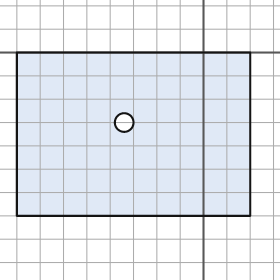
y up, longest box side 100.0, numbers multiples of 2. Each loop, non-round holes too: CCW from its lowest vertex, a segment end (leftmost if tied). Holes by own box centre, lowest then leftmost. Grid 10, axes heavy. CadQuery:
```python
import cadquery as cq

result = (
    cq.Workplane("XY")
    .moveTo(-80.0, -70.0)
    .lineTo(20.0, -70.0)
    .lineTo(20.0, 0.0)
    .lineTo(-80.0, 0.0)
    .close()
    .moveTo(-34.0, -30.0)
    .circle(4.0)
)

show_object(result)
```